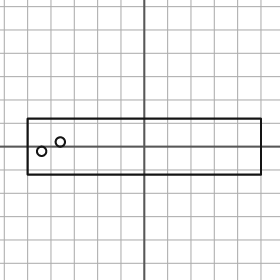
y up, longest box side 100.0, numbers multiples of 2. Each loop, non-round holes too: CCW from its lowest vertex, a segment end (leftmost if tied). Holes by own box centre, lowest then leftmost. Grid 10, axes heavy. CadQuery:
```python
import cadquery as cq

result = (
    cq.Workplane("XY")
    .moveTo(-50.0, -12.0)
    .lineTo(50.0, -12.0)
    .lineTo(50.0, 12.0)
    .lineTo(-50.0, 12.0)
    .close()
    .moveTo(-44.0, -2.0)
    .circle(2.0)
    .moveTo(-36.0, 2.0)
    .circle(2.0)
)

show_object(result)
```